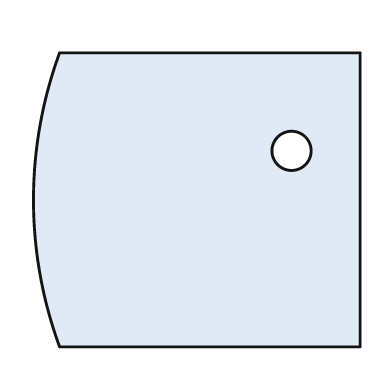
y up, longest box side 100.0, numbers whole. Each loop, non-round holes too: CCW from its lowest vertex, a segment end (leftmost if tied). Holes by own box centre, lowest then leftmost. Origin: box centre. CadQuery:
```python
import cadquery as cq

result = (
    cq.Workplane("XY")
    .moveTo(-42.0, -45.0)
    .lineTo(50.0, -45.0)
    .lineTo(50.0, 45.0)
    .lineTo(-42.0, 45.0)
    .threePointArc((-50.0, 0.0), (-42.0, -45.0))
    .close()
    .moveTo(29.0, 15.0)
    .circle(6.0)
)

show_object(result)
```